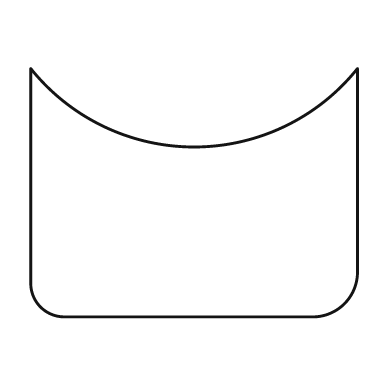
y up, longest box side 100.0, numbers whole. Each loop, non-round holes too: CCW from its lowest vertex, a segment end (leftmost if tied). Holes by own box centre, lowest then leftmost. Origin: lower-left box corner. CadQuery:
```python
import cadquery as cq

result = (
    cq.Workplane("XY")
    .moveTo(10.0, 0.0)
    .lineTo(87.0, 0.0)
    .threePointArc((96.0, 4.0), (100.0, 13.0))
    .lineTo(100.0, 76.0)
    .threePointArc((50.0, 52.0), (0.0, 76.0))
    .lineTo(0.0, 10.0)
    .threePointArc((3.0, 3.0), (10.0, 0.0))
    .close()
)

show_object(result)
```